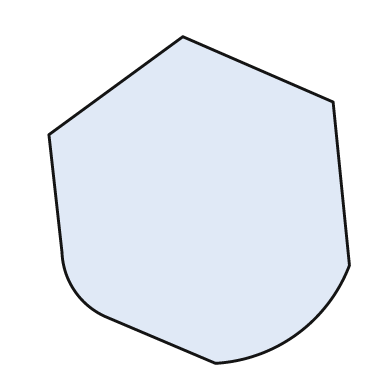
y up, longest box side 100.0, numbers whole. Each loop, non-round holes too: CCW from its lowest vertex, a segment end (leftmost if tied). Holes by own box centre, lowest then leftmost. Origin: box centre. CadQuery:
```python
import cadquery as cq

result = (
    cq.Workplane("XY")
    .moveTo(5.0, -50.0)
    .threePointArc((30.0, -41.0), (46.0, -20.0))
    .lineTo(41.0, 30.0)
    .lineTo(-5.0, 50.0)
    .lineTo(-46.0, 20.0)
    .lineTo(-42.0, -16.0)
    .threePointArc((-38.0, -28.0), (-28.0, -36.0))
    .close()
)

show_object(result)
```